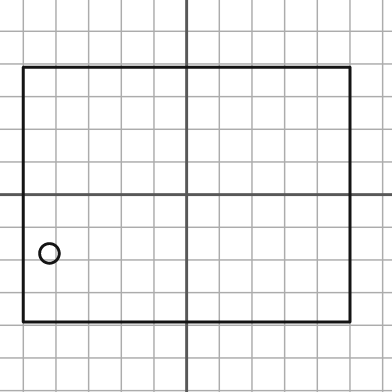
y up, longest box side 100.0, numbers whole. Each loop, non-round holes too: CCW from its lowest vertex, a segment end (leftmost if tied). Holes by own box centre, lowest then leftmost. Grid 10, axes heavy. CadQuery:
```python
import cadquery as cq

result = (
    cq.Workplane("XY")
    .moveTo(-50.0, -39.0)
    .lineTo(50.0, -39.0)
    .lineTo(50.0, 39.0)
    .lineTo(-50.0, 39.0)
    .close()
    .moveTo(-42.0, -18.0)
    .circle(3.0)
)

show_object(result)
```